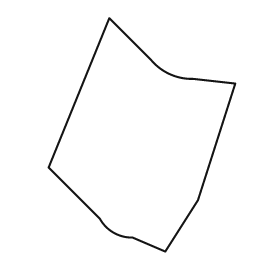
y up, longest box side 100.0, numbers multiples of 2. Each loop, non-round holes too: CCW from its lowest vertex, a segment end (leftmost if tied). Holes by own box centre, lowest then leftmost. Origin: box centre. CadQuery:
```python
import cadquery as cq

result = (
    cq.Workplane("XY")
    .moveTo(10.0, -50.0)
    .lineTo(24.0, -28.0)
    .lineTo(40.0, 22.0)
    .lineTo(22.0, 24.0)
    .threePointArc((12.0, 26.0), (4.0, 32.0))
    .lineTo(-14.0, 50.0)
    .lineTo(-40.0, -14.0)
    .lineTo(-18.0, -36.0)
    .threePointArc((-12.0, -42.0), (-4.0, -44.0))
    .close()
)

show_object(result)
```